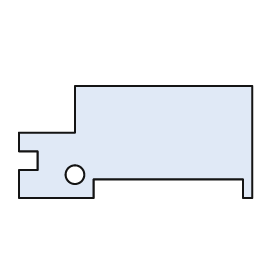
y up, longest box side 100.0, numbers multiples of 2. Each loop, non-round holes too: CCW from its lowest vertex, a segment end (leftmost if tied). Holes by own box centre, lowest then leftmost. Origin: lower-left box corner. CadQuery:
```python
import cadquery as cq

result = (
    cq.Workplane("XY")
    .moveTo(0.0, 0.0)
    .lineTo(32.0, 0.0)
    .lineTo(32.0, 8.0)
    .lineTo(96.0, 8.0)
    .lineTo(96.0, 0.0)
    .lineTo(100.0, 0.0)
    .lineTo(100.0, 48.0)
    .lineTo(24.0, 48.0)
    .lineTo(24.0, 28.0)
    .lineTo(0.0, 28.0)
    .lineTo(0.0, 20.0)
    .lineTo(8.0, 20.0)
    .lineTo(8.0, 12.0)
    .lineTo(0.0, 12.0)
    .close()
    .moveTo(24.0, 10.0)
    .circle(4.0)
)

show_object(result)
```